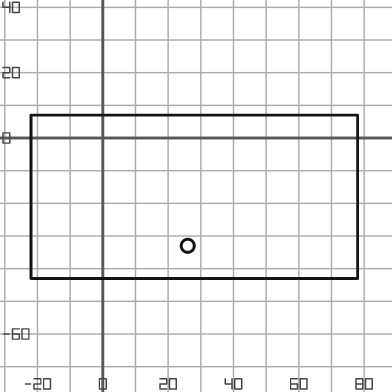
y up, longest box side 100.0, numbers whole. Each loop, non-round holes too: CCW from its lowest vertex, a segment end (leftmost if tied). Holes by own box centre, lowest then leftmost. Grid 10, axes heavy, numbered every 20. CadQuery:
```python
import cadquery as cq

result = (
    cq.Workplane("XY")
    .moveTo(-22.0, -43.0)
    .lineTo(78.0, -43.0)
    .lineTo(78.0, 7.0)
    .lineTo(-22.0, 7.0)
    .close()
    .moveTo(26.0, -33.0)
    .circle(2.0)
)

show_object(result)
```